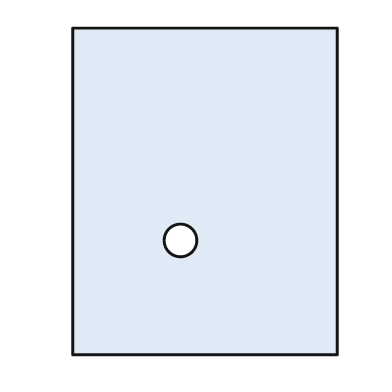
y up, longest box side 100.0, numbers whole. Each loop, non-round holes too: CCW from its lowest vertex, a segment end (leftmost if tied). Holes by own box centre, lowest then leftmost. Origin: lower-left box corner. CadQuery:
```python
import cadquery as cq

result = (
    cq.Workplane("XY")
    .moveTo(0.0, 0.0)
    .lineTo(81.0, 0.0)
    .lineTo(81.0, 100.0)
    .lineTo(0.0, 100.0)
    .close()
    .moveTo(33.0, 35.0)
    .circle(5.0)
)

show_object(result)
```